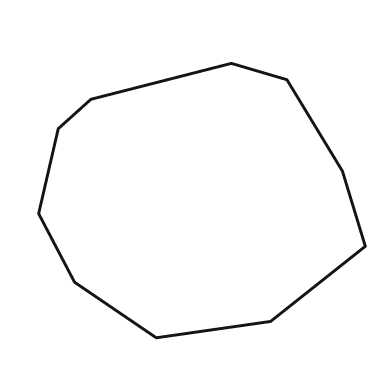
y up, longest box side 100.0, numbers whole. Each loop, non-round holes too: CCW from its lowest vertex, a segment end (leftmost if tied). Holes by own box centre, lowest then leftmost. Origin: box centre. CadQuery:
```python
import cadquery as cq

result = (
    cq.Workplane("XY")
    .moveTo(-14.0, -42.0)
    .lineTo(21.0, -37.0)
    .lineTo(50.0, -14.0)
    .lineTo(43.0, 9.0)
    .lineTo(26.0, 37.0)
    .lineTo(9.0, 42.0)
    .lineTo(-34.0, 31.0)
    .lineTo(-44.0, 22.0)
    .lineTo(-50.0, -4.0)
    .lineTo(-39.0, -25.0)
    .close()
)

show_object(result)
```